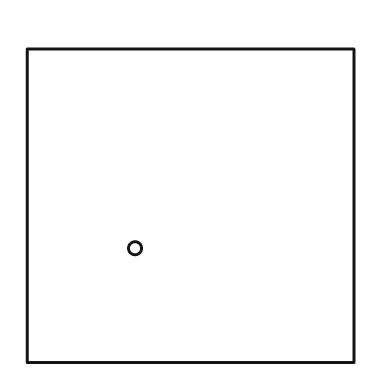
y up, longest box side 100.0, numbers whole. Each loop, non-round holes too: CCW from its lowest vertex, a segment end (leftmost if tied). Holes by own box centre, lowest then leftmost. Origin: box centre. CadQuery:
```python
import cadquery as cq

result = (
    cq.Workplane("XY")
    .moveTo(-50.0, -48.0)
    .lineTo(50.0, -48.0)
    .lineTo(50.0, 48.0)
    .lineTo(-50.0, 48.0)
    .close()
    .moveTo(-17.0, -13.0)
    .circle(2.0)
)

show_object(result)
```